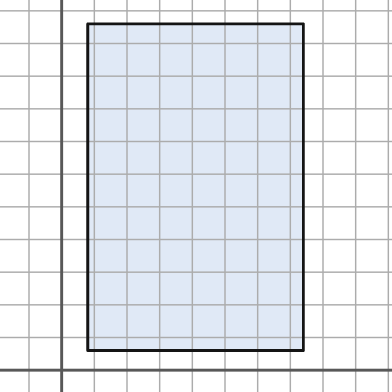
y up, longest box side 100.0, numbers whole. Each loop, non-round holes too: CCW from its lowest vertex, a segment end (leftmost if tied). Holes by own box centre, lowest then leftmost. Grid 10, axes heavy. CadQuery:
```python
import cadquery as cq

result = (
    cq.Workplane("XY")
    .moveTo(8.0, 6.0)
    .lineTo(74.0, 6.0)
    .lineTo(74.0, 106.0)
    .lineTo(8.0, 106.0)
    .close()
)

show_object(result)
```